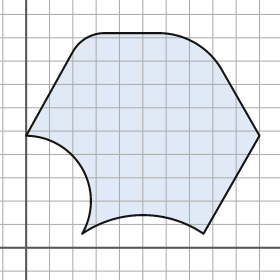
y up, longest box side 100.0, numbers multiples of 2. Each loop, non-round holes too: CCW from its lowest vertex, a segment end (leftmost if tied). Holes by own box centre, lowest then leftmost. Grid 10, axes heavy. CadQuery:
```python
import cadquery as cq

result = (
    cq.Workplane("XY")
    .moveTo(24.0, 6.0)
    .threePointArc((50.0, 14.0), (76.0, 6.0))
    .lineTo(100.0, 48.0)
    .lineTo(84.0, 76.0)
    .threePointArc((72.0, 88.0), (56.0, 92.0))
    .lineTo(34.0, 92.0)
    .threePointArc((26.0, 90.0), (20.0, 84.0))
    .lineTo(0.0, 48.0)
    .threePointArc((24.0, 34.0), (24.0, 6.0))
    .close()
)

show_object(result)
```